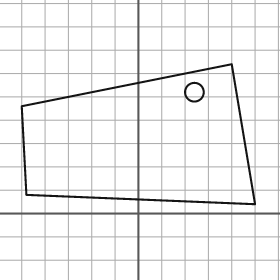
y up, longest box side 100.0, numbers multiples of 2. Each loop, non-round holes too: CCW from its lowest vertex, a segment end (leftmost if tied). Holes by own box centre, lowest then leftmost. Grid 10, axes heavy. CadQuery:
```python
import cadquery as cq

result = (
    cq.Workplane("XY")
    .moveTo(50.0, 4.0)
    .lineTo(40.0, 64.0)
    .lineTo(-50.0, 46.0)
    .lineTo(-48.0, 8.0)
    .close()
    .moveTo(24.0, 52.0)
    .circle(4.0)
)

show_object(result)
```